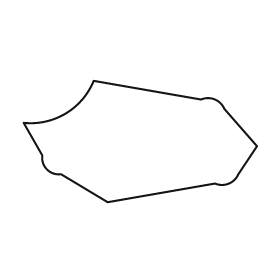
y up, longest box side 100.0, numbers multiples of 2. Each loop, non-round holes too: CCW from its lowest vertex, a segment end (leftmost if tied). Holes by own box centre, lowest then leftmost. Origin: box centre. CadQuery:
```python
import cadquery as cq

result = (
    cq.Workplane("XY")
    .moveTo(-14.0, -26.0)
    .lineTo(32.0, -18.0)
    .threePointArc((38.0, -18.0), (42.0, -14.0))
    .lineTo(50.0, -2.0)
    .lineTo(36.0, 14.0)
    .threePointArc((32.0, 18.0), (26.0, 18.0))
    .lineTo(-20.0, 26.0)
    .threePointArc((-32.0, 12.0), (-50.0, 8.0))
    .lineTo(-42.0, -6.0)
    .threePointArc((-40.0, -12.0), (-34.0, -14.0))
    .close()
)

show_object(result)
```